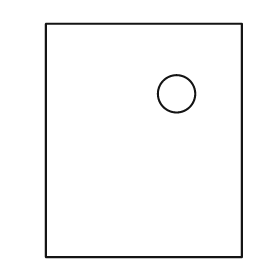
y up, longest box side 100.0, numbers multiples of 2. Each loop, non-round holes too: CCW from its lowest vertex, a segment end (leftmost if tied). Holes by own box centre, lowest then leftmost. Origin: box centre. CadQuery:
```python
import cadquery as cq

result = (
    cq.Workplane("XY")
    .moveTo(-42.0, -50.0)
    .lineTo(42.0, -50.0)
    .lineTo(42.0, 50.0)
    .lineTo(-42.0, 50.0)
    .close()
    .moveTo(14.0, 20.0)
    .circle(8.0)
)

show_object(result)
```